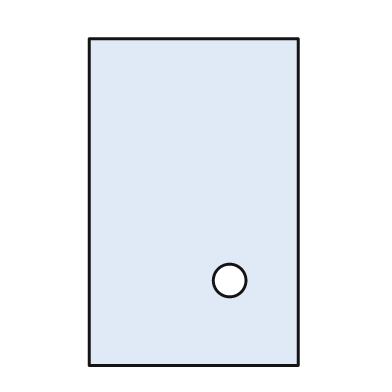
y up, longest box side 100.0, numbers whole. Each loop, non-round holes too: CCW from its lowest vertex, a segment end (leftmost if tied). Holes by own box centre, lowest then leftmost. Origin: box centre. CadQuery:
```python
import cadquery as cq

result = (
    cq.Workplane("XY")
    .moveTo(-32.0, -50.0)
    .lineTo(32.0, -50.0)
    .lineTo(32.0, 50.0)
    .lineTo(-32.0, 50.0)
    .close()
    .moveTo(11.0, -24.0)
    .circle(5.0)
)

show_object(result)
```